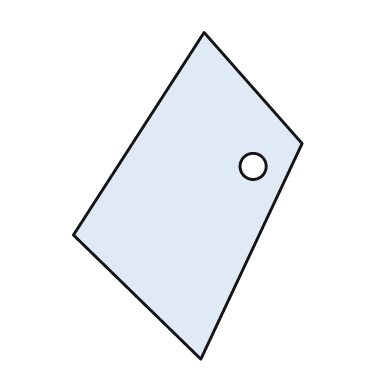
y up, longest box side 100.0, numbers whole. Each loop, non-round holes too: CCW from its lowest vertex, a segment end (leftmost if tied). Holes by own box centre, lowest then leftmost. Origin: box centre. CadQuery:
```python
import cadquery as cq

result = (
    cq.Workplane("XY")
    .moveTo(4.0, -50.0)
    .lineTo(35.0, 16.0)
    .lineTo(5.0, 50.0)
    .lineTo(-35.0, -12.0)
    .close()
    .moveTo(20.0, 9.0)
    .circle(4.0)
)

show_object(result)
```